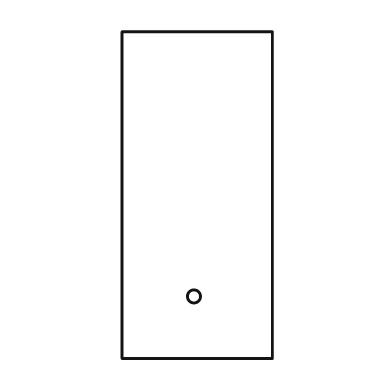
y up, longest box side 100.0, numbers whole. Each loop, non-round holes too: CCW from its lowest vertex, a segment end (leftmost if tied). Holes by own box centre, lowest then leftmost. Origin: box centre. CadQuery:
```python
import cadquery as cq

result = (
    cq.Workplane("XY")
    .moveTo(-23.0, -50.0)
    .lineTo(23.0, -50.0)
    .lineTo(23.0, 50.0)
    .lineTo(-23.0, 50.0)
    .close()
    .moveTo(-1.0, -31.0)
    .circle(2.0)
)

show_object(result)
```